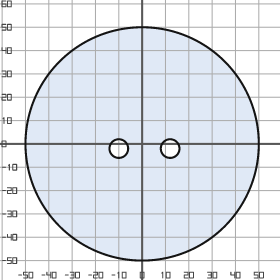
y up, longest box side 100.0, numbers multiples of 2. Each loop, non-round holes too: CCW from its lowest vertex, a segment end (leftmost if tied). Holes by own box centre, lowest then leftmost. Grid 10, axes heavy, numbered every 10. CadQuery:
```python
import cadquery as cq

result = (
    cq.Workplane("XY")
    .moveTo(0.0, 0.0)
    .circle(50.0)
    .moveTo(-10.0, -2.0)
    .circle(4.0)
    .moveTo(12.0, -2.0)
    .circle(4.0)
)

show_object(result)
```